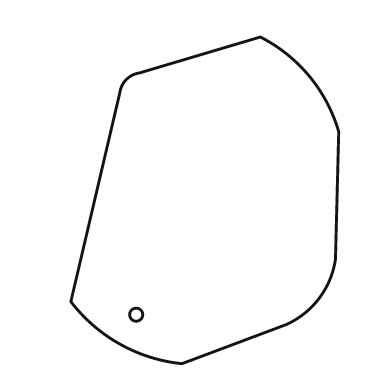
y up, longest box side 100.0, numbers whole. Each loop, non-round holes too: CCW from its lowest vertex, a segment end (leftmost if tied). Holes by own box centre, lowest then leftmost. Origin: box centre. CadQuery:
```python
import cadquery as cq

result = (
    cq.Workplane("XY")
    .moveTo(-7.0, -50.0)
    .lineTo(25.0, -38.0)
    .threePointArc((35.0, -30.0), (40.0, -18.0))
    .lineTo(41.0, 21.0)
    .threePointArc((32.0, 38.0), (17.0, 50.0))
    .lineTo(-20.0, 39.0)
    .threePointArc((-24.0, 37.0), (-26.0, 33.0))
    .lineTo(-41.0, -31.0)
    .threePointArc((-26.0, -44.0), (-7.0, -50.0))
    .close()
    .moveTo(-21.0, -35.0)
    .circle(2.0)
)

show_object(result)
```